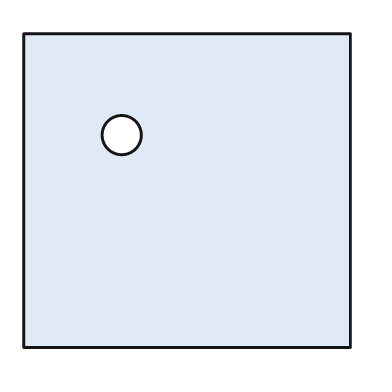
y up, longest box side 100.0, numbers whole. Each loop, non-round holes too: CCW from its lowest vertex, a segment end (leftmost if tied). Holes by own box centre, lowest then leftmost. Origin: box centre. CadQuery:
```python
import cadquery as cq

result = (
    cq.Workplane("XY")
    .moveTo(-50.0, -48.0)
    .lineTo(50.0, -48.0)
    .lineTo(50.0, 48.0)
    .lineTo(-50.0, 48.0)
    .close()
    .moveTo(-20.0, 17.0)
    .circle(6.0)
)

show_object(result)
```